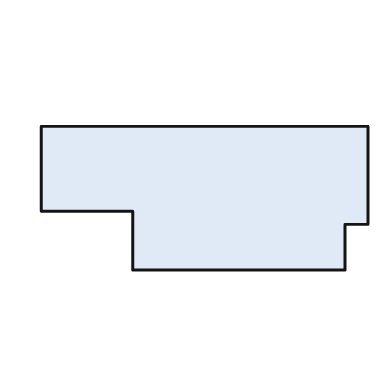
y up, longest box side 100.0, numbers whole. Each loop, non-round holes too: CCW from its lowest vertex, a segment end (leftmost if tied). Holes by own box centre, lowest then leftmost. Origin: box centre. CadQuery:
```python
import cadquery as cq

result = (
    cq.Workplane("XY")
    .moveTo(-22.0, -22.0)
    .lineTo(43.0, -22.0)
    .lineTo(43.0, -8.0)
    .lineTo(50.0, -8.0)
    .lineTo(50.0, 22.0)
    .lineTo(-50.0, 22.0)
    .lineTo(-50.0, -4.0)
    .lineTo(-22.0, -4.0)
    .close()
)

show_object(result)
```